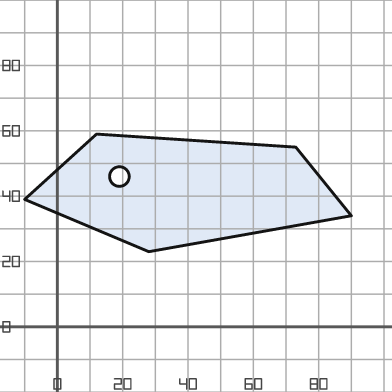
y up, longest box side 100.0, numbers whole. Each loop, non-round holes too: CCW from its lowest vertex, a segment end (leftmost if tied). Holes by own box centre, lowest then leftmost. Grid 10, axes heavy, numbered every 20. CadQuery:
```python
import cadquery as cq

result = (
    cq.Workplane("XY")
    .moveTo(28.0, 23.0)
    .lineTo(90.0, 34.0)
    .lineTo(73.0, 55.0)
    .lineTo(12.0, 59.0)
    .lineTo(-10.0, 39.0)
    .close()
    .moveTo(19.0, 46.0)
    .circle(3.0)
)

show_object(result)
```